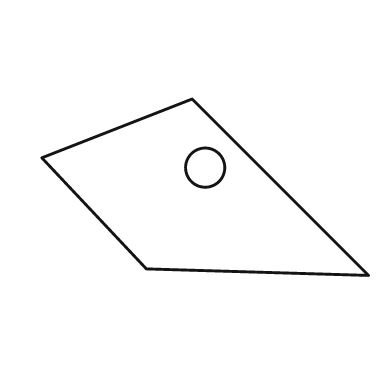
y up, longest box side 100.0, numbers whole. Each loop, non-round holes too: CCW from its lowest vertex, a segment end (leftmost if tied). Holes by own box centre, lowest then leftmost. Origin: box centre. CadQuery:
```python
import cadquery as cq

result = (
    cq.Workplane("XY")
    .moveTo(50.0, -27.0)
    .lineTo(-4.0, 27.0)
    .lineTo(-50.0, 9.0)
    .lineTo(-18.0, -25.0)
    .close()
    .moveTo(0.0, 6.0)
    .circle(6.0)
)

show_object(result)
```